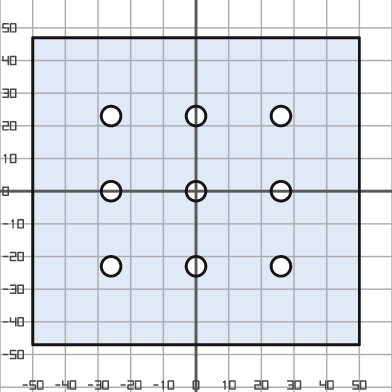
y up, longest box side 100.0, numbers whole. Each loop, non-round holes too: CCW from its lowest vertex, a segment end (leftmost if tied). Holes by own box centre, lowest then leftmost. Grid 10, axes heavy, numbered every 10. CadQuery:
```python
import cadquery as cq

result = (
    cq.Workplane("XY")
    .moveTo(-50.0, -47.0)
    .lineTo(50.0, -47.0)
    .lineTo(50.0, 47.0)
    .lineTo(-50.0, 47.0)
    .close()
    .moveTo(-26.0, -23.0)
    .circle(3.0)
    .moveTo(0.0, -23.0)
    .circle(3.0)
    .moveTo(26.0, -23.0)
    .circle(3.0)
    .moveTo(-26.0, 0.0)
    .circle(3.0)
    .moveTo(0.0, 0.0)
    .circle(3.0)
    .moveTo(26.0, 0.0)
    .circle(3.0)
    .moveTo(-26.0, 23.0)
    .circle(3.0)
    .moveTo(0.0, 23.0)
    .circle(3.0)
    .moveTo(26.0, 23.0)
    .circle(3.0)
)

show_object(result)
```